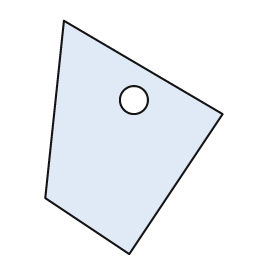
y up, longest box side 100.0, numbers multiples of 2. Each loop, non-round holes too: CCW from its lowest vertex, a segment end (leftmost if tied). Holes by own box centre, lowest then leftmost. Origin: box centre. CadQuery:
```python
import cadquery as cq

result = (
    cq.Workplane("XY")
    .moveTo(-2.0, -50.0)
    .lineTo(38.0, 10.0)
    .lineTo(-30.0, 50.0)
    .lineTo(-38.0, -26.0)
    .close()
    .moveTo(0.0, 16.0)
    .circle(6.0)
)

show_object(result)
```